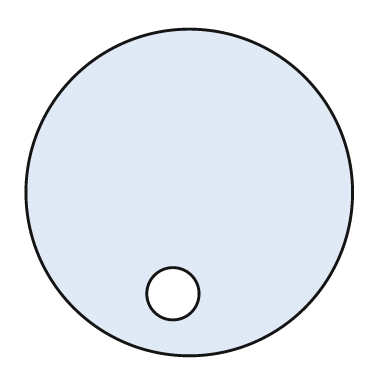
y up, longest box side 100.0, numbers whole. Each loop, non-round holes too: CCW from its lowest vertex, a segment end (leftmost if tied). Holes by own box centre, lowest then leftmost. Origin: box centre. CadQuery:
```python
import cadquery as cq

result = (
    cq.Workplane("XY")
    .moveTo(0.0, 0.0)
    .circle(50.0)
    .moveTo(-5.0, -31.0)
    .circle(8.0)
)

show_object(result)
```